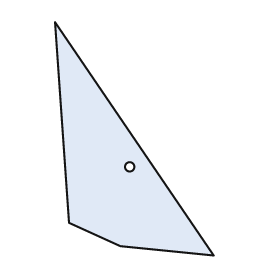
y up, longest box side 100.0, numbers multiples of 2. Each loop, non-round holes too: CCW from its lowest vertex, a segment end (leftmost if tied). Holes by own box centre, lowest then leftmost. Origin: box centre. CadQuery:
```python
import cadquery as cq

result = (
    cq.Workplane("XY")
    .moveTo(34.0, -50.0)
    .lineTo(-34.0, 50.0)
    .lineTo(-28.0, -36.0)
    .lineTo(-6.0, -46.0)
    .close()
    .moveTo(-2.0, -12.0)
    .circle(2.0)
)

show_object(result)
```